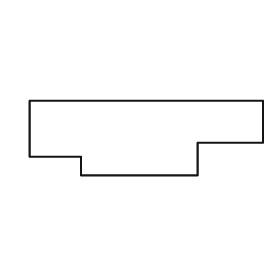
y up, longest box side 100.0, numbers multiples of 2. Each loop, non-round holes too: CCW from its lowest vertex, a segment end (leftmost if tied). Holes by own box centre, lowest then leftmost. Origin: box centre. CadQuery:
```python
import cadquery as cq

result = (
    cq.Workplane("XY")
    .moveTo(-28.0, -16.0)
    .lineTo(22.0, -16.0)
    .lineTo(22.0, -2.0)
    .lineTo(50.0, -2.0)
    .lineTo(50.0, 16.0)
    .lineTo(-50.0, 16.0)
    .lineTo(-50.0, -8.0)
    .lineTo(-28.0, -8.0)
    .close()
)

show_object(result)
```